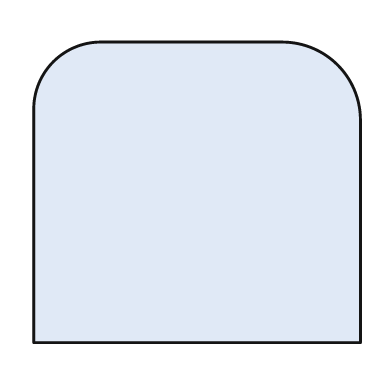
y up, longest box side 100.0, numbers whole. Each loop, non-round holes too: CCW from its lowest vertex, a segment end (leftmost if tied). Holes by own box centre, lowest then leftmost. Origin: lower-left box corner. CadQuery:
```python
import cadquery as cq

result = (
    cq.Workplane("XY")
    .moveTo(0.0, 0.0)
    .lineTo(100.0, 0.0)
    .lineTo(100.0, 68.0)
    .threePointArc((93.0, 85.0), (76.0, 92.0))
    .lineTo(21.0, 92.0)
    .threePointArc((6.0, 86.0), (0.0, 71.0))
    .close()
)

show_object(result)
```